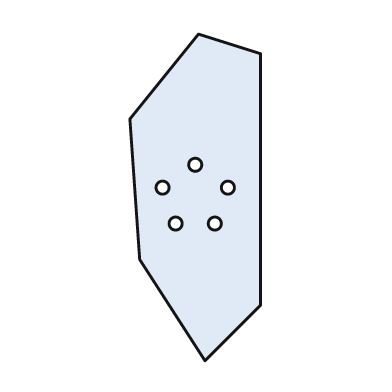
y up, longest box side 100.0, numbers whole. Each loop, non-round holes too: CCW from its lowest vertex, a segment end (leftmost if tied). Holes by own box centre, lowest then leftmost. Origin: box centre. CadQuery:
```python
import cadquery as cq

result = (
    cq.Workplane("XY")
    .moveTo(3.0, -50.0)
    .lineTo(20.0, -33.0)
    .lineTo(20.0, 44.0)
    .lineTo(1.0, 50.0)
    .lineTo(-20.0, 24.0)
    .lineTo(-17.0, -19.0)
    .close()
    .moveTo(-6.0, -8.0)
    .circle(2.0)
    .moveTo(6.0, -8.0)
    .circle(2.0)
    .moveTo(-10.0, 3.0)
    .circle(2.0)
    .moveTo(10.0, 3.0)
    .circle(2.0)
    .moveTo(0.0, 10.0)
    .circle(2.0)
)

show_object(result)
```